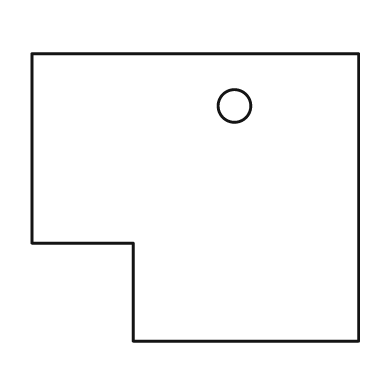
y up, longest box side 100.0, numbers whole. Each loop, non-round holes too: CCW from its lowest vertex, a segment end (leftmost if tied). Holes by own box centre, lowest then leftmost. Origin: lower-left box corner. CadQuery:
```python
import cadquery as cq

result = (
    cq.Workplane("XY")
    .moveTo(31.0, 0.0)
    .lineTo(100.0, 0.0)
    .lineTo(100.0, 88.0)
    .lineTo(0.0, 88.0)
    .lineTo(0.0, 30.0)
    .lineTo(31.0, 30.0)
    .close()
    .moveTo(62.0, 72.0)
    .circle(5.0)
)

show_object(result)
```